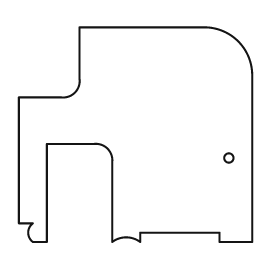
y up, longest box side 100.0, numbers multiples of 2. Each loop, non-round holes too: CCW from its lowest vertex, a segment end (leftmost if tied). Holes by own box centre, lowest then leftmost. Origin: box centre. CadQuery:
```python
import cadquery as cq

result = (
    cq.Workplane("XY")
    .moveTo(-44.0, -46.0)
    .lineTo(-38.0, -46.0)
    .lineTo(-38.0, -4.0)
    .lineTo(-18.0, -4.0)
    .threePointArc((-12.0, -6.0), (-10.0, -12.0))
    .lineTo(-10.0, -46.0)
    .threePointArc((-4.0, -44.0), (2.0, -46.0))
    .lineTo(2.0, -42.0)
    .lineTo(36.0, -42.0)
    .lineTo(36.0, -46.0)
    .lineTo(50.0, -46.0)
    .lineTo(50.0, 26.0)
    .threePointArc((44.0, 40.0), (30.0, 46.0))
    .lineTo(-24.0, 46.0)
    .lineTo(-24.0, 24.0)
    .threePointArc((-26.0, 18.0), (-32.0, 16.0))
    .lineTo(-50.0, 16.0)
    .lineTo(-50.0, -38.0)
    .lineTo(-44.0, -38.0)
    .threePointArc((-46.0, -42.0), (-44.0, -46.0))
    .close()
    .moveTo(40.0, -10.0)
    .circle(2.0)
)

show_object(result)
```